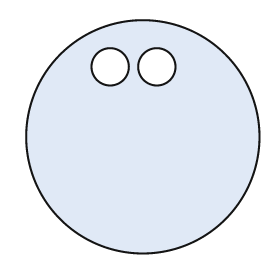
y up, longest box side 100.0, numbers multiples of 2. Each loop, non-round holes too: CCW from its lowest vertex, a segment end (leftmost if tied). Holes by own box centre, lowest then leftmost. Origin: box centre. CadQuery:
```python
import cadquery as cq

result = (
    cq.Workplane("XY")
    .moveTo(0.0, 0.0)
    .circle(50.0)
    .moveTo(-14.0, 30.0)
    .circle(8.0)
    .moveTo(6.0, 30.0)
    .circle(8.0)
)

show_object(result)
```